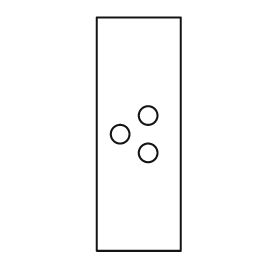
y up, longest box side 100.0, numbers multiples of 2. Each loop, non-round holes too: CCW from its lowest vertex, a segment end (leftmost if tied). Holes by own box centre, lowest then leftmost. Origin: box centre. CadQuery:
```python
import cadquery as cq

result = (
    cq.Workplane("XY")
    .moveTo(-18.0, -50.0)
    .lineTo(18.0, -50.0)
    .lineTo(18.0, 50.0)
    .lineTo(-18.0, 50.0)
    .close()
    .moveTo(4.0, -8.0)
    .circle(4.0)
    .moveTo(-8.0, 0.0)
    .circle(4.0)
    .moveTo(4.0, 8.0)
    .circle(4.0)
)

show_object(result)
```